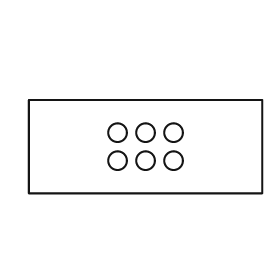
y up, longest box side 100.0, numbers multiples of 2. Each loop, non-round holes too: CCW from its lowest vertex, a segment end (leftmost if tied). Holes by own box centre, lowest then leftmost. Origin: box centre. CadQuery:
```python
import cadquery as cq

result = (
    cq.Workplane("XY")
    .moveTo(-50.0, -20.0)
    .lineTo(50.0, -20.0)
    .lineTo(50.0, 20.0)
    .lineTo(-50.0, 20.0)
    .close()
    .moveTo(-12.0, -6.0)
    .circle(4.0)
    .moveTo(0.0, -6.0)
    .circle(4.0)
    .moveTo(12.0, -6.0)
    .circle(4.0)
    .moveTo(-12.0, 6.0)
    .circle(4.0)
    .moveTo(0.0, 6.0)
    .circle(4.0)
    .moveTo(12.0, 6.0)
    .circle(4.0)
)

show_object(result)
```